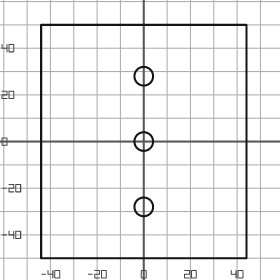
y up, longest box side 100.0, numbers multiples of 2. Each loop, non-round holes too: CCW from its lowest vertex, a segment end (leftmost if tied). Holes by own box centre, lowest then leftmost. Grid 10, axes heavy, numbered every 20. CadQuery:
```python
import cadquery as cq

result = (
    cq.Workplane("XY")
    .moveTo(-44.0, -50.0)
    .lineTo(44.0, -50.0)
    .lineTo(44.0, 50.0)
    .lineTo(-44.0, 50.0)
    .close()
    .moveTo(0.0, -28.0)
    .circle(4.0)
    .moveTo(0.0, 0.0)
    .circle(4.0)
    .moveTo(0.0, 28.0)
    .circle(4.0)
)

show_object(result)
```